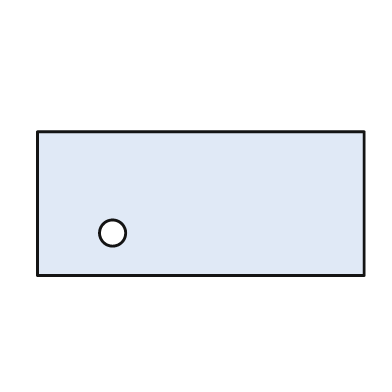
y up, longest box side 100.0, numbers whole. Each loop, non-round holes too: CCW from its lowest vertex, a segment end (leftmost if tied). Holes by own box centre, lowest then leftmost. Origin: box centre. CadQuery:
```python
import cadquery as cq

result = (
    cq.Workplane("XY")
    .moveTo(-50.0, -22.0)
    .lineTo(50.0, -22.0)
    .lineTo(50.0, 22.0)
    .lineTo(-50.0, 22.0)
    .close()
    .moveTo(-27.0, -9.0)
    .circle(4.0)
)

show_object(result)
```